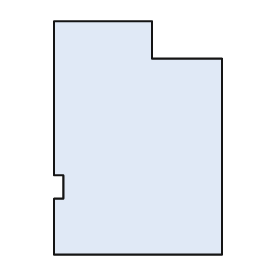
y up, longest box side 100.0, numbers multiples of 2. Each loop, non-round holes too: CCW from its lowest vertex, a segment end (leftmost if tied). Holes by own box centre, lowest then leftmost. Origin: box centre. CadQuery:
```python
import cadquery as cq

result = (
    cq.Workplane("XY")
    .moveTo(-36.0, -50.0)
    .lineTo(36.0, -50.0)
    .lineTo(36.0, 34.0)
    .lineTo(6.0, 34.0)
    .lineTo(6.0, 50.0)
    .lineTo(-36.0, 50.0)
    .lineTo(-36.0, -16.0)
    .lineTo(-32.0, -16.0)
    .lineTo(-32.0, -26.0)
    .lineTo(-36.0, -26.0)
    .close()
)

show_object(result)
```